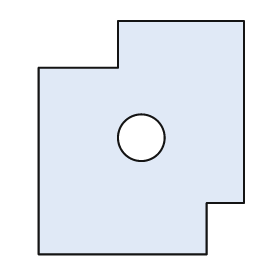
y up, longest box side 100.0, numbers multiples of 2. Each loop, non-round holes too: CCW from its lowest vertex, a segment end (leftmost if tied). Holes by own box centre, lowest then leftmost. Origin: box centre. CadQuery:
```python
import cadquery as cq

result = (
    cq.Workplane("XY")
    .moveTo(-44.0, -50.0)
    .lineTo(28.0, -50.0)
    .lineTo(28.0, -28.0)
    .lineTo(44.0, -28.0)
    .lineTo(44.0, 50.0)
    .lineTo(-10.0, 50.0)
    .lineTo(-10.0, 30.0)
    .lineTo(-44.0, 30.0)
    .close()
    .moveTo(0.0, 0.0)
    .circle(10.0)
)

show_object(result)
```